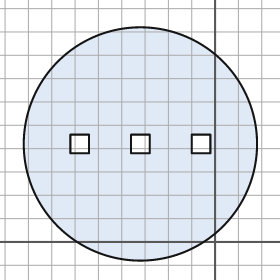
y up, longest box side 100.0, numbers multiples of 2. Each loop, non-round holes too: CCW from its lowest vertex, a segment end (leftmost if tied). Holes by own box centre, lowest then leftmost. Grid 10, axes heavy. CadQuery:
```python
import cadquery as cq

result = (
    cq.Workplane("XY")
    .moveTo(-32.0, 42.0)
    .circle(50.0)
    .moveTo(-62.0, 38.0)
    .lineTo(-54.0, 38.0)
    .lineTo(-54.0, 46.0)
    .lineTo(-62.0, 46.0)
    .close()
    .moveTo(-36.0, 38.0)
    .lineTo(-28.0, 38.0)
    .lineTo(-28.0, 46.0)
    .lineTo(-36.0, 46.0)
    .close()
    .moveTo(-10.0, 38.0)
    .lineTo(-2.0, 38.0)
    .lineTo(-2.0, 46.0)
    .lineTo(-10.0, 46.0)
    .close()
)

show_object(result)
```